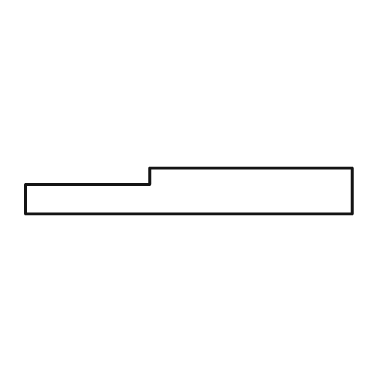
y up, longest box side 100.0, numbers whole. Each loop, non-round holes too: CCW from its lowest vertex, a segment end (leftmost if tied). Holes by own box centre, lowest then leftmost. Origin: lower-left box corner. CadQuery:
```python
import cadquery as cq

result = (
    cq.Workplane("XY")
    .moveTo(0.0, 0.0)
    .lineTo(100.0, 0.0)
    .lineTo(100.0, 14.0)
    .lineTo(38.0, 14.0)
    .lineTo(38.0, 9.0)
    .lineTo(0.0, 9.0)
    .close()
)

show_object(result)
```